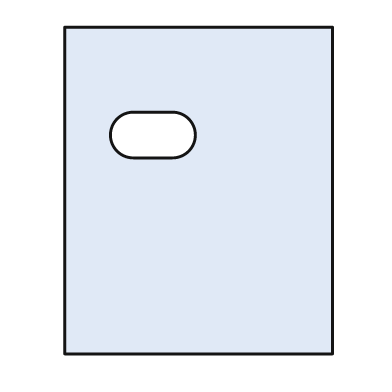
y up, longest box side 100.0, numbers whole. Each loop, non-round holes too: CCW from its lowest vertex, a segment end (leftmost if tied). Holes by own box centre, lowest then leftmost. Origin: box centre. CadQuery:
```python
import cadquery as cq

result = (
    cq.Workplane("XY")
    .moveTo(-41.0, -50.0)
    .lineTo(41.0, -50.0)
    .lineTo(41.0, 50.0)
    .lineTo(-41.0, 50.0)
    .close()
    .moveTo(-20.0, 10.0)
    .lineTo(-8.0, 10.0)
    .threePointArc((-1.0, 17.0), (-8.0, 24.0))
    .lineTo(-20.0, 24.0)
    .threePointArc((-27.0, 17.0), (-20.0, 10.0))
    .close()
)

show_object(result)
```